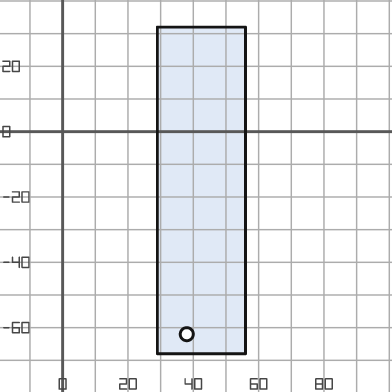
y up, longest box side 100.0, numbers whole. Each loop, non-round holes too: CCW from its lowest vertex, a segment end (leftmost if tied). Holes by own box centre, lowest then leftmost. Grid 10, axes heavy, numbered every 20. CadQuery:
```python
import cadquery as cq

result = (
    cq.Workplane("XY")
    .moveTo(29.0, -68.0)
    .lineTo(56.0, -68.0)
    .lineTo(56.0, 32.0)
    .lineTo(29.0, 32.0)
    .close()
    .moveTo(38.0, -62.0)
    .circle(2.0)
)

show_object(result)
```